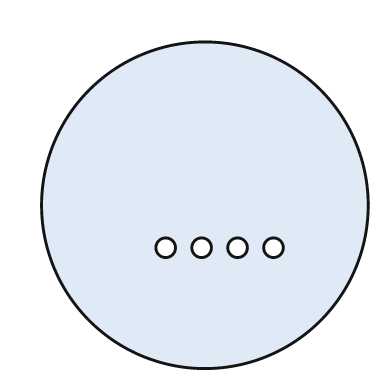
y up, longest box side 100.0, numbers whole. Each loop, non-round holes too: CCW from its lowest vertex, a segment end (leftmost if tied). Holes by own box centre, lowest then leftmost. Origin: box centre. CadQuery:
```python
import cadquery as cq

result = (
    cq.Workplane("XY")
    .moveTo(0.0, 0.0)
    .circle(50.0)
    .moveTo(-12.0, -13.0)
    .circle(3.0)
    .moveTo(-1.0, -13.0)
    .circle(3.0)
    .moveTo(10.0, -13.0)
    .circle(3.0)
    .moveTo(21.0, -13.0)
    .circle(3.0)
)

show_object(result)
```